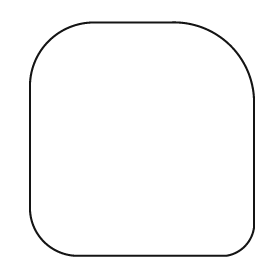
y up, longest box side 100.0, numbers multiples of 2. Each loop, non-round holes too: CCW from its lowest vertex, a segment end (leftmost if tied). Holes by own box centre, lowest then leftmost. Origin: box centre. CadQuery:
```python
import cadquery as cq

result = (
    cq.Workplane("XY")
    .moveTo(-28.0, -50.0)
    .lineTo(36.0, -50.0)
    .threePointArc((44.0, -46.0), (48.0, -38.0))
    .lineTo(48.0, 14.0)
    .threePointArc((38.0, 40.0), (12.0, 50.0))
    .lineTo(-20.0, 50.0)
    .threePointArc((-40.0, 42.0), (-48.0, 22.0))
    .lineTo(-48.0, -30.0)
    .threePointArc((-42.0, -44.0), (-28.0, -50.0))
    .close()
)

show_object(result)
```